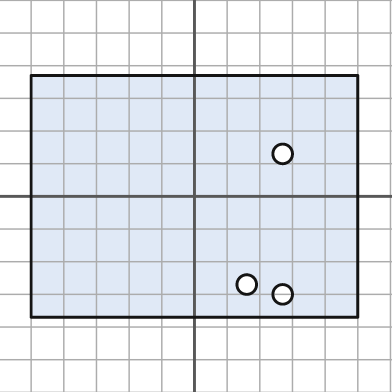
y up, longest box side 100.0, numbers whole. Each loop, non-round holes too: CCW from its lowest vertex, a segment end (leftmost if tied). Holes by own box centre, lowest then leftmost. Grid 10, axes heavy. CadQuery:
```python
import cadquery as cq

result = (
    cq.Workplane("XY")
    .moveTo(-50.0, -37.0)
    .lineTo(50.0, -37.0)
    .lineTo(50.0, 37.0)
    .lineTo(-50.0, 37.0)
    .close()
    .moveTo(27.0, -30.0)
    .circle(3.0)
    .moveTo(16.0, -27.0)
    .circle(3.0)
    .moveTo(27.0, 13.0)
    .circle(3.0)
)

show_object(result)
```